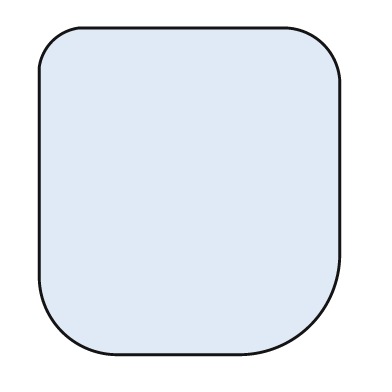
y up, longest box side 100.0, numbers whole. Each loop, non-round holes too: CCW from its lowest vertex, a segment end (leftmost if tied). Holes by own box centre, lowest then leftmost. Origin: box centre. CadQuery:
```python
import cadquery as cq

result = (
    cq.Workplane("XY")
    .moveTo(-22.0, -50.0)
    .lineTo(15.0, -50.0)
    .threePointArc((37.0, -41.0), (46.0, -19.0))
    .lineTo(46.0, 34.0)
    .threePointArc((41.0, 45.0), (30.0, 50.0))
    .lineTo(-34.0, 50.0)
    .threePointArc((-42.0, 46.0), (-46.0, 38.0))
    .lineTo(-46.0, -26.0)
    .threePointArc((-39.0, -43.0), (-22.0, -50.0))
    .close()
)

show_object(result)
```